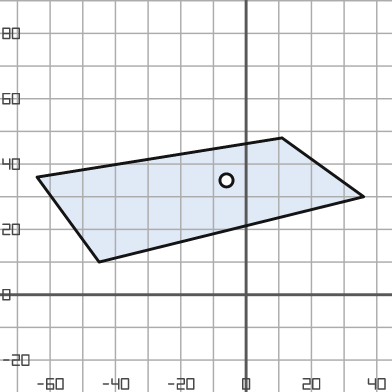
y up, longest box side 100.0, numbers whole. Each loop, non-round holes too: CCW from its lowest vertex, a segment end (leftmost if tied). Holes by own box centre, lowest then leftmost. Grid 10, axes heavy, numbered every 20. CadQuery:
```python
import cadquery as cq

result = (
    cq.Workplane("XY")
    .moveTo(-45.0, 10.0)
    .lineTo(36.0, 30.0)
    .lineTo(11.0, 48.0)
    .lineTo(-64.0, 36.0)
    .close()
    .moveTo(-6.0, 35.0)
    .circle(2.0)
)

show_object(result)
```